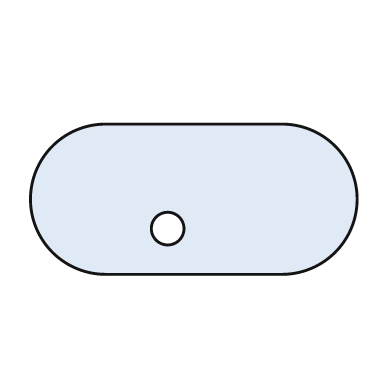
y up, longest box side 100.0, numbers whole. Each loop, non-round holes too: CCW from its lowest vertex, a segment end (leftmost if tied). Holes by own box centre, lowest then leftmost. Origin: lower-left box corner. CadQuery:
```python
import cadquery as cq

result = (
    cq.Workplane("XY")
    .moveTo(23.0, 0.0)
    .lineTo(77.0, 0.0)
    .threePointArc((100.0, 23.0), (77.0, 46.0))
    .lineTo(23.0, 46.0)
    .threePointArc((0.0, 23.0), (23.0, 0.0))
    .close()
    .moveTo(42.0, 14.0)
    .circle(5.0)
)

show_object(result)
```